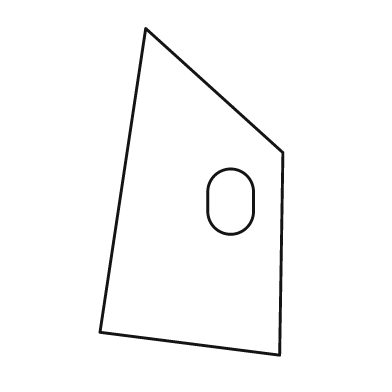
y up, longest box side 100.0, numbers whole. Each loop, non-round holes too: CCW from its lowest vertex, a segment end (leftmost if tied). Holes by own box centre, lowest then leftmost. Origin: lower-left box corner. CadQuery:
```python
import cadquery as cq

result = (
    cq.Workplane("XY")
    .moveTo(55.0, 0.0)
    .lineTo(56.0, 62.0)
    .lineTo(14.0, 100.0)
    .lineTo(0.0, 7.0)
    .close()
    .moveTo(33.0, 44.0)
    .threePointArc((40.0, 37.0), (47.0, 44.0))
    .lineTo(47.0, 50.0)
    .threePointArc((40.0, 57.0), (33.0, 50.0))
    .close()
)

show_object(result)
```